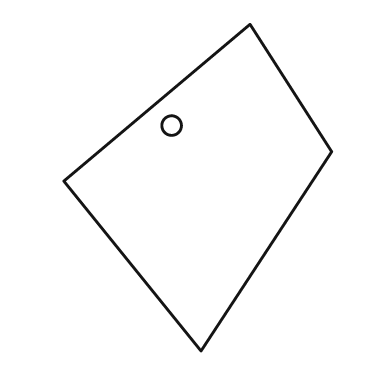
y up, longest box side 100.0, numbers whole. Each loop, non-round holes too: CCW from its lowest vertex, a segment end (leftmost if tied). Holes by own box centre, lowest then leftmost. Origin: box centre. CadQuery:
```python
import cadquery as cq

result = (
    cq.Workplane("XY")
    .moveTo(1.0, -50.0)
    .lineTo(41.0, 11.0)
    .lineTo(16.0, 50.0)
    .lineTo(-41.0, 2.0)
    .close()
    .moveTo(-8.0, 19.0)
    .circle(3.0)
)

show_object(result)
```